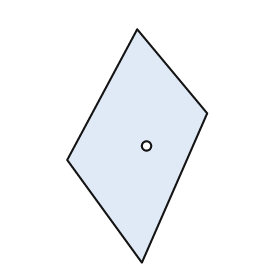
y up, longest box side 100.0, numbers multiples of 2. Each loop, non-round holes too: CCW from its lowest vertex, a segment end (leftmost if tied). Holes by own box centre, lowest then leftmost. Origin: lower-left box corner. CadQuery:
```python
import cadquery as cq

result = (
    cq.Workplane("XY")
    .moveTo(32.0, 0.0)
    .lineTo(60.0, 64.0)
    .lineTo(30.0, 100.0)
    .lineTo(0.0, 44.0)
    .close()
    .moveTo(34.0, 50.0)
    .circle(2.0)
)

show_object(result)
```